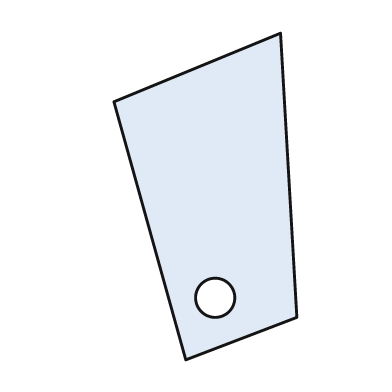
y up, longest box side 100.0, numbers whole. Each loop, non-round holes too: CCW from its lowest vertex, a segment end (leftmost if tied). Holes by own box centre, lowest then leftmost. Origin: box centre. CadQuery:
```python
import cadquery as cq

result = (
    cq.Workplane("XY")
    .moveTo(-6.0, -50.0)
    .lineTo(28.0, -37.0)
    .lineTo(23.0, 50.0)
    .lineTo(-28.0, 29.0)
    .close()
    .moveTo(3.0, -31.0)
    .circle(6.0)
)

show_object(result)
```